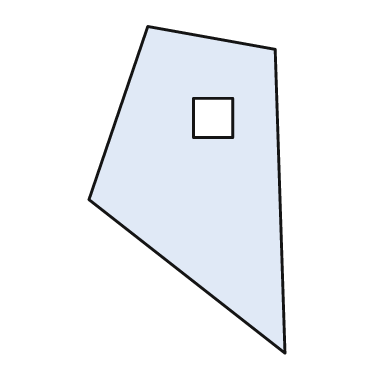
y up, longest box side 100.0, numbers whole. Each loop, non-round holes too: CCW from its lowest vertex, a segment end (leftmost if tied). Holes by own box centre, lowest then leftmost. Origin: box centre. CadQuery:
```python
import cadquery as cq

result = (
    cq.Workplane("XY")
    .moveTo(30.0, -50.0)
    .lineTo(27.0, 43.0)
    .lineTo(-12.0, 50.0)
    .lineTo(-30.0, -3.0)
    .close()
    .moveTo(2.0, 16.0)
    .lineTo(14.0, 16.0)
    .lineTo(14.0, 28.0)
    .lineTo(2.0, 28.0)
    .close()
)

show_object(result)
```